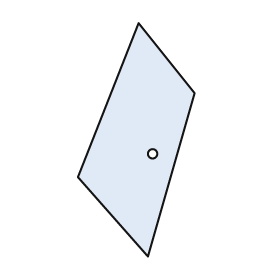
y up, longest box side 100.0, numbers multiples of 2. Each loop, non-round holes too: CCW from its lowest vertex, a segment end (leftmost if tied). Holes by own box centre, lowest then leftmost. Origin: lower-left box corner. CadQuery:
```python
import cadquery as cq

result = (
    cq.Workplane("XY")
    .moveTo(30.0, 0.0)
    .lineTo(50.0, 70.0)
    .lineTo(26.0, 100.0)
    .lineTo(0.0, 34.0)
    .close()
    .moveTo(32.0, 44.0)
    .circle(2.0)
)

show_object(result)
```